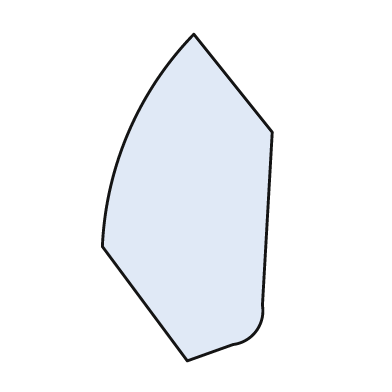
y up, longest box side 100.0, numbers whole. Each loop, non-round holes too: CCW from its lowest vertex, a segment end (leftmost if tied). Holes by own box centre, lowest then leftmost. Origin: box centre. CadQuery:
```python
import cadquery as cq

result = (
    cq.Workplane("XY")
    .moveTo(0.0, -50.0)
    .lineTo(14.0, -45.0)
    .threePointArc((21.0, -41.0), (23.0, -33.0))
    .lineTo(26.0, 20.0)
    .lineTo(2.0, 50.0)
    .threePointArc((-18.0, 20.0), (-26.0, -15.0))
    .close()
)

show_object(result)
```